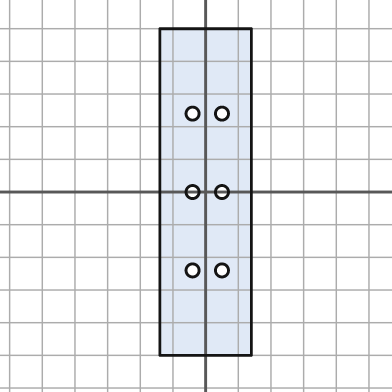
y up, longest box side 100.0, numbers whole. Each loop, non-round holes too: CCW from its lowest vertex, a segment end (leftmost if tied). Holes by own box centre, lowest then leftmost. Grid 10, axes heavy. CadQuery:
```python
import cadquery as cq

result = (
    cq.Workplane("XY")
    .moveTo(-14.0, -50.0)
    .lineTo(14.0, -50.0)
    .lineTo(14.0, 50.0)
    .lineTo(-14.0, 50.0)
    .close()
    .moveTo(-4.0, -24.0)
    .circle(2.0)
    .moveTo(5.0, -24.0)
    .circle(2.0)
    .moveTo(-4.0, 0.0)
    .circle(2.0)
    .moveTo(5.0, 0.0)
    .circle(2.0)
    .moveTo(-4.0, 24.0)
    .circle(2.0)
    .moveTo(5.0, 24.0)
    .circle(2.0)
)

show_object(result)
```